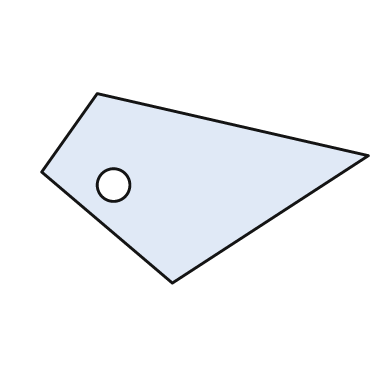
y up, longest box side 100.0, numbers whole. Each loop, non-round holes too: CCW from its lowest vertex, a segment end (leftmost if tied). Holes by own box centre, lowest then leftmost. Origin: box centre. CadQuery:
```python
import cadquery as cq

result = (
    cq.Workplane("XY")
    .moveTo(-10.0, -29.0)
    .lineTo(50.0, 10.0)
    .lineTo(-33.0, 29.0)
    .lineTo(-50.0, 5.0)
    .close()
    .moveTo(-28.0, 1.0)
    .circle(5.0)
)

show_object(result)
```